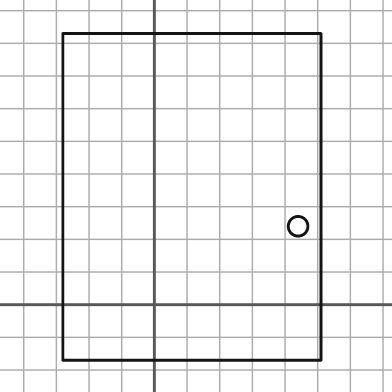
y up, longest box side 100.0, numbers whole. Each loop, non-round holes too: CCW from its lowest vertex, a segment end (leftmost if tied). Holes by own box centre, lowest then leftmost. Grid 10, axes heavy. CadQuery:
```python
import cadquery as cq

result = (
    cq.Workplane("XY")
    .moveTo(-28.0, -17.0)
    .lineTo(51.0, -17.0)
    .lineTo(51.0, 83.0)
    .lineTo(-28.0, 83.0)
    .close()
    .moveTo(44.0, 24.0)
    .circle(3.0)
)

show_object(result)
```